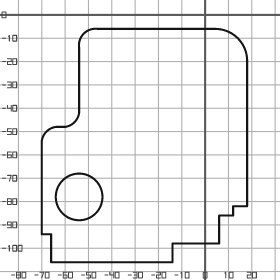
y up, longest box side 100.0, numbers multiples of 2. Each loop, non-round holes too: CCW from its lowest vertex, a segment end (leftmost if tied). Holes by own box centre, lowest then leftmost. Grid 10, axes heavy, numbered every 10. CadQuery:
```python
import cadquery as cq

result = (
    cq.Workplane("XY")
    .moveTo(-66.0, -106.0)
    .lineTo(-14.0, -106.0)
    .lineTo(-14.0, -98.0)
    .lineTo(6.0, -98.0)
    .lineTo(6.0, -86.0)
    .lineTo(12.0, -86.0)
    .lineTo(12.0, -82.0)
    .lineTo(18.0, -82.0)
    .lineTo(18.0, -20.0)
    .threePointArc((14.0, -10.0), (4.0, -6.0))
    .lineTo(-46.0, -6.0)
    .threePointArc((-52.0, -8.0), (-54.0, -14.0))
    .lineTo(-54.0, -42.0)
    .threePointArc((-56.0, -46.0), (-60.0, -48.0))
    .lineTo(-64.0, -48.0)
    .threePointArc((-68.0, -50.0), (-70.0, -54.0))
    .lineTo(-70.0, -94.0)
    .lineTo(-66.0, -94.0)
    .close()
    .moveTo(-54.0, -78.0)
    .circle(10.0)
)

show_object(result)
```